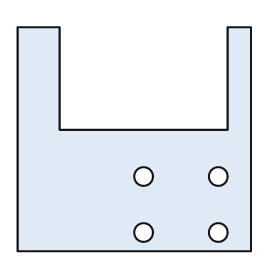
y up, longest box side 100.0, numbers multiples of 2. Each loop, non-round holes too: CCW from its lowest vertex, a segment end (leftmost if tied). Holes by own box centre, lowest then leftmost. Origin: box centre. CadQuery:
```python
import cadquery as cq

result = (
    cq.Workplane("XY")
    .moveTo(-50.0, -48.0)
    .lineTo(50.0, -48.0)
    .lineTo(50.0, 48.0)
    .lineTo(40.0, 48.0)
    .lineTo(40.0, 4.0)
    .lineTo(-32.0, 4.0)
    .lineTo(-32.0, 48.0)
    .lineTo(-50.0, 48.0)
    .close()
    .moveTo(4.0, -40.0)
    .circle(4.0)
    .moveTo(36.0, -40.0)
    .circle(4.0)
    .moveTo(4.0, -16.0)
    .circle(4.0)
    .moveTo(36.0, -16.0)
    .circle(4.0)
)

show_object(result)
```